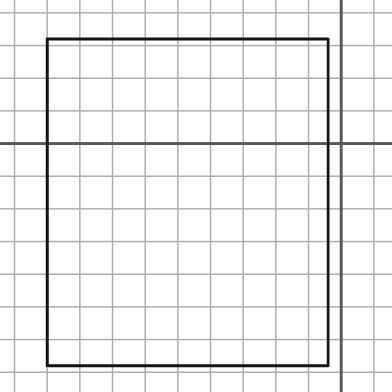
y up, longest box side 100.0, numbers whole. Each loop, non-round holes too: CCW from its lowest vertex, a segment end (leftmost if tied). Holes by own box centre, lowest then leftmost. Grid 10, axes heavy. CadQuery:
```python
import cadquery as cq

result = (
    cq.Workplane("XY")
    .moveTo(-90.0, -68.0)
    .lineTo(-4.0, -68.0)
    .lineTo(-4.0, 32.0)
    .lineTo(-90.0, 32.0)
    .close()
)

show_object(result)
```